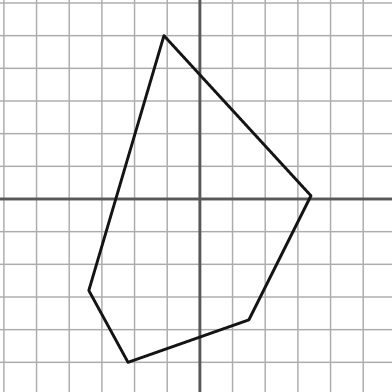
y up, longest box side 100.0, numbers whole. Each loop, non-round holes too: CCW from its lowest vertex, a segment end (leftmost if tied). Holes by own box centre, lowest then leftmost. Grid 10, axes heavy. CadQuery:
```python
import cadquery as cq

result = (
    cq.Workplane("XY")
    .moveTo(-22.0, -50.0)
    .lineTo(15.0, -37.0)
    .lineTo(34.0, 1.0)
    .lineTo(-11.0, 50.0)
    .lineTo(-34.0, -28.0)
    .close()
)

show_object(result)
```